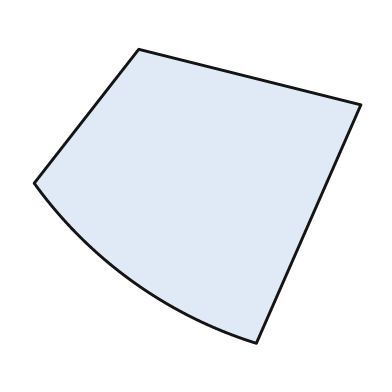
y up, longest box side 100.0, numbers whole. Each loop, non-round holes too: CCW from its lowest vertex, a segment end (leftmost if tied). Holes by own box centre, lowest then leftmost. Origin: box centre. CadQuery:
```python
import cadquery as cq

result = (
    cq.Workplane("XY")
    .moveTo(18.0, -45.0)
    .lineTo(50.0, 28.0)
    .lineTo(-18.0, 45.0)
    .lineTo(-50.0, 4.0)
    .threePointArc((-20.0, -26.0), (18.0, -45.0))
    .close()
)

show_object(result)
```